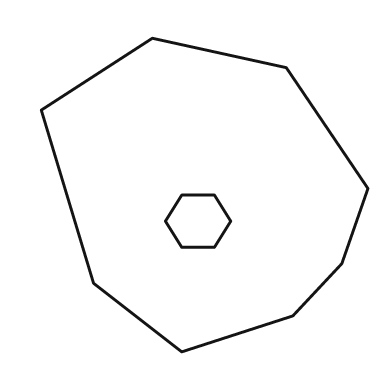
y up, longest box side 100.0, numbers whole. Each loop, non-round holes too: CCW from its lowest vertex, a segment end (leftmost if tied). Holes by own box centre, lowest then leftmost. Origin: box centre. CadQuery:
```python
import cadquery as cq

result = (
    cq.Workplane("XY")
    .moveTo(-7.0, -48.0)
    .lineTo(27.0, -37.0)
    .lineTo(42.0, -21.0)
    .lineTo(50.0, 2.0)
    .lineTo(25.0, 39.0)
    .lineTo(-16.0, 48.0)
    .lineTo(-50.0, 26.0)
    .lineTo(-34.0, -27.0)
    .close()
    .moveTo(-7.0, -16.0)
    .lineTo(3.0, -16.0)
    .lineTo(8.0, -8.0)
    .lineTo(3.0, 0.0)
    .lineTo(-7.0, 0.0)
    .lineTo(-12.0, -8.0)
    .close()
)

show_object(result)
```